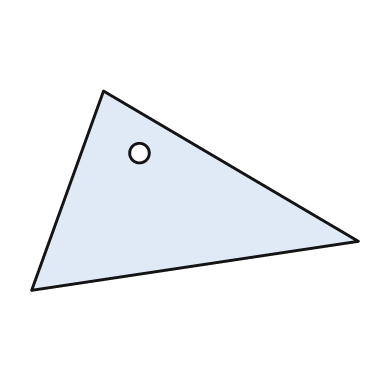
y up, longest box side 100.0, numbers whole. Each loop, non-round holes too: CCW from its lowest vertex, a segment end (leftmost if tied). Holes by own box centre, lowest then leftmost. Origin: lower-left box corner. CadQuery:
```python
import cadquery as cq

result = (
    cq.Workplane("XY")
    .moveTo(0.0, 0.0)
    .lineTo(100.0, 15.0)
    .lineTo(22.0, 61.0)
    .close()
    .moveTo(33.0, 42.0)
    .circle(3.0)
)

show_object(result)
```